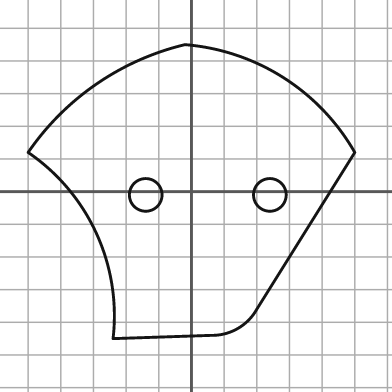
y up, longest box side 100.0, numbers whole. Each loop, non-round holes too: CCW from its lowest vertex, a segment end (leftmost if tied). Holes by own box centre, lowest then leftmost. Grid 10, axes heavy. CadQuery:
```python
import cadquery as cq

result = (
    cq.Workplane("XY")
    .moveTo(-24.0, -45.0)
    .lineTo(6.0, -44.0)
    .threePointArc((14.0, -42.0), (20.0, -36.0))
    .lineTo(50.0, 12.0)
    .threePointArc((28.0, 35.0), (-2.0, 45.0))
    .threePointArc((-29.0, 33.0), (-50.0, 12.0))
    .threePointArc((-29.0, -13.0), (-24.0, -45.0))
    .close()
    .moveTo(-14.0, -1.0)
    .circle(5.0)
    .moveTo(24.0, -1.0)
    .circle(5.0)
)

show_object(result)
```